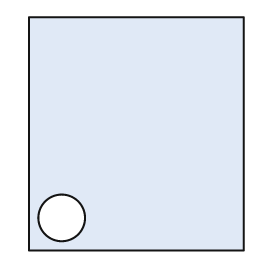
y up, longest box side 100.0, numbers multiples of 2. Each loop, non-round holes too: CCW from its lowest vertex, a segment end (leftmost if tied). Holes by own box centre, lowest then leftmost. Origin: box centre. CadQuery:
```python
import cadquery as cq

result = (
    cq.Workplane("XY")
    .moveTo(-46.0, -50.0)
    .lineTo(46.0, -50.0)
    .lineTo(46.0, 50.0)
    .lineTo(-46.0, 50.0)
    .close()
    .moveTo(-32.0, -36.0)
    .circle(10.0)
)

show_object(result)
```